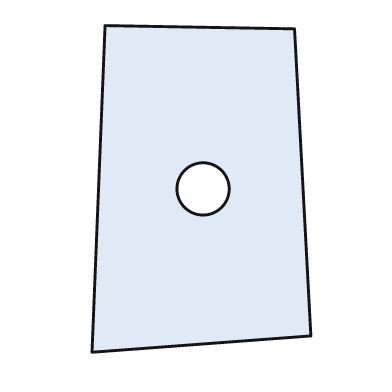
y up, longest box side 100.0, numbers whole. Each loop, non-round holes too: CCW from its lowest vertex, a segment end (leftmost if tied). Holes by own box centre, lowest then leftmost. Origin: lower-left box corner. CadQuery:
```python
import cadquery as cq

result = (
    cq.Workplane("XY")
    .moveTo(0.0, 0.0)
    .lineTo(67.0, 5.0)
    .lineTo(62.0, 99.0)
    .lineTo(4.0, 100.0)
    .close()
    .moveTo(34.0, 50.0)
    .circle(8.0)
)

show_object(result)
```